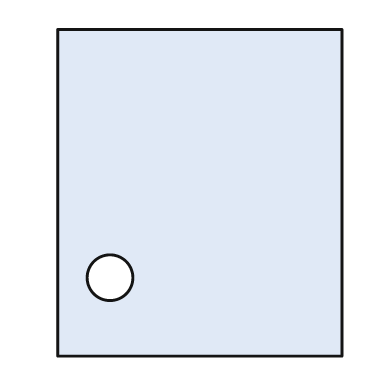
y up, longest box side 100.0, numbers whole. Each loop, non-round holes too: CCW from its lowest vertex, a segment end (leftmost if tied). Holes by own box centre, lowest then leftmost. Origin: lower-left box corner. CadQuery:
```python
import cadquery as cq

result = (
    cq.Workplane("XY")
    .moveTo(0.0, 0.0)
    .lineTo(87.0, 0.0)
    .lineTo(87.0, 100.0)
    .lineTo(0.0, 100.0)
    .close()
    .moveTo(16.0, 24.0)
    .circle(7.0)
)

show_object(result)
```